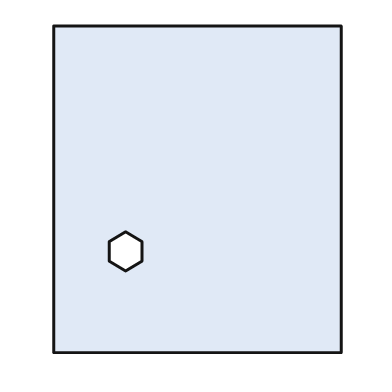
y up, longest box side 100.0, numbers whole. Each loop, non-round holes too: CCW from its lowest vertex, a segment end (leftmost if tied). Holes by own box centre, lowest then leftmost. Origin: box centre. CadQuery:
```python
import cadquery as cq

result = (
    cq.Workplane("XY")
    .moveTo(-44.0, -50.0)
    .lineTo(44.0, -50.0)
    .lineTo(44.0, 50.0)
    .lineTo(-44.0, 50.0)
    .close()
    .moveTo(-22.0, -25.0)
    .lineTo(-17.0, -22.0)
    .lineTo(-17.0, -16.0)
    .lineTo(-22.0, -13.0)
    .lineTo(-27.0, -16.0)
    .lineTo(-27.0, -22.0)
    .close()
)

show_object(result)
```